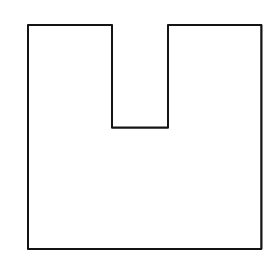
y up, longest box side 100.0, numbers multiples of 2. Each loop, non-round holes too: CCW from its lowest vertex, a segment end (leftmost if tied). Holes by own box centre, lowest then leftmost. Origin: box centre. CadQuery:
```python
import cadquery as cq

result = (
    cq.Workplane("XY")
    .moveTo(-50.0, -48.0)
    .lineTo(50.0, -48.0)
    .lineTo(50.0, 48.0)
    .lineTo(10.0, 48.0)
    .lineTo(10.0, 4.0)
    .lineTo(-14.0, 4.0)
    .lineTo(-14.0, 48.0)
    .lineTo(-50.0, 48.0)
    .close()
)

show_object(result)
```